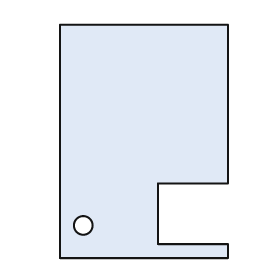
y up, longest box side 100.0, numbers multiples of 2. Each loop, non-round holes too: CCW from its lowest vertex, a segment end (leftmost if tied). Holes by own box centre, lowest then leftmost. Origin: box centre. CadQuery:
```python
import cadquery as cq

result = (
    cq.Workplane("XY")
    .moveTo(-36.0, -50.0)
    .lineTo(36.0, -50.0)
    .lineTo(36.0, -44.0)
    .lineTo(6.0, -44.0)
    .lineTo(6.0, -18.0)
    .lineTo(36.0, -18.0)
    .lineTo(36.0, 50.0)
    .lineTo(-36.0, 50.0)
    .close()
    .moveTo(-26.0, -36.0)
    .circle(4.0)
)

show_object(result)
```